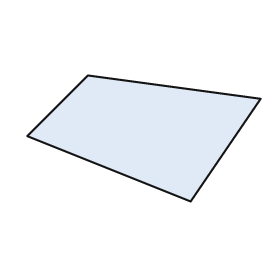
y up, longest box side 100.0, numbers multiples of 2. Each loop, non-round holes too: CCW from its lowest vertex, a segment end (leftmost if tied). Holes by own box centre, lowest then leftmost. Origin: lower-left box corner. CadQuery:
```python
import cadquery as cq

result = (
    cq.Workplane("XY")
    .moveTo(70.0, 0.0)
    .lineTo(100.0, 44.0)
    .lineTo(26.0, 54.0)
    .lineTo(0.0, 28.0)
    .close()
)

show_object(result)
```